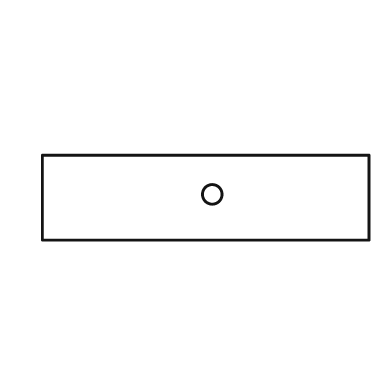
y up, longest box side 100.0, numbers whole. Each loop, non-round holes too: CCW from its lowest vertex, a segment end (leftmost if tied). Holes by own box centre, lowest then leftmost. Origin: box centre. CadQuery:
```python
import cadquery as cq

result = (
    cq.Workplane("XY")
    .moveTo(-50.0, -13.0)
    .lineTo(50.0, -13.0)
    .lineTo(50.0, 13.0)
    .lineTo(-50.0, 13.0)
    .close()
    .moveTo(2.0, 1.0)
    .circle(3.0)
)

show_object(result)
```